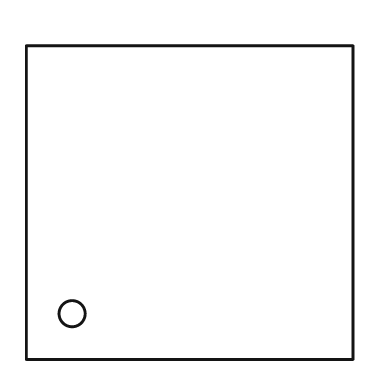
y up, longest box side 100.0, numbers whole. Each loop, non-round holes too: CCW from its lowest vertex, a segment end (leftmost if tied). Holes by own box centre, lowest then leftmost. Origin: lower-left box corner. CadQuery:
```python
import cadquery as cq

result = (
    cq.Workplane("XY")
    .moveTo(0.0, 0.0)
    .lineTo(100.0, 0.0)
    .lineTo(100.0, 96.0)
    .lineTo(0.0, 96.0)
    .close()
    .moveTo(14.0, 14.0)
    .circle(4.0)
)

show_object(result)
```